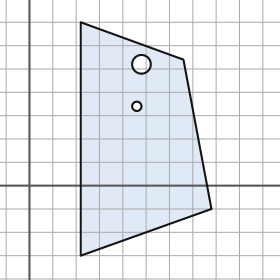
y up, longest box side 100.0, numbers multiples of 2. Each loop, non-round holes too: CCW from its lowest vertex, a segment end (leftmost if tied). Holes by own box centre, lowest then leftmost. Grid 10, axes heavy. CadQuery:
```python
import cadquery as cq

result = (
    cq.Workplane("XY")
    .moveTo(22.0, -30.0)
    .lineTo(78.0, -10.0)
    .lineTo(66.0, 54.0)
    .lineTo(22.0, 70.0)
    .close()
    .moveTo(46.0, 34.0)
    .circle(2.0)
    .moveTo(48.0, 52.0)
    .circle(4.0)
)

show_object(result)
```